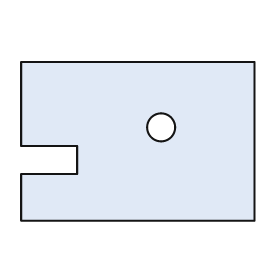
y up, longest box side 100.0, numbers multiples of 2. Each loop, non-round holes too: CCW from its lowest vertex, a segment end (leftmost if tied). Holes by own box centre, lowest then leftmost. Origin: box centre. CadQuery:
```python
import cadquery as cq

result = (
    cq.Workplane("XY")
    .moveTo(-50.0, -34.0)
    .lineTo(50.0, -34.0)
    .lineTo(50.0, 34.0)
    .lineTo(-50.0, 34.0)
    .lineTo(-50.0, -2.0)
    .lineTo(-26.0, -2.0)
    .lineTo(-26.0, -14.0)
    .lineTo(-50.0, -14.0)
    .close()
    .moveTo(10.0, 6.0)
    .circle(6.0)
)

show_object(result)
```